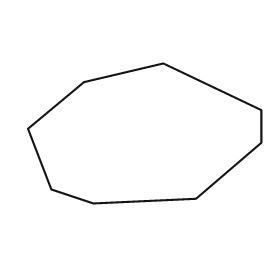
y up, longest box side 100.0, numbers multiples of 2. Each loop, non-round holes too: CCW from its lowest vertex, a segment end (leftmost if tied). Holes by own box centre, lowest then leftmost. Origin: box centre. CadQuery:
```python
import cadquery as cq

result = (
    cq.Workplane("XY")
    .moveTo(-22.0, -30.0)
    .lineTo(22.0, -28.0)
    .lineTo(50.0, -4.0)
    .lineTo(50.0, 10.0)
    .lineTo(8.0, 30.0)
    .lineTo(-26.0, 22.0)
    .lineTo(-50.0, 2.0)
    .lineTo(-40.0, -24.0)
    .close()
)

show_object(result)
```